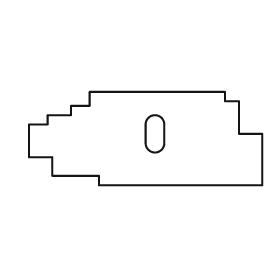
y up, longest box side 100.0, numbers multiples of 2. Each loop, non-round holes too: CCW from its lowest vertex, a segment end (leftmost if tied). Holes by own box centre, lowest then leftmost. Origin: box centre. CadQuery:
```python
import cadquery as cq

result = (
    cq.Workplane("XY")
    .moveTo(-20.0, -20.0)
    .lineTo(50.0, -20.0)
    .lineTo(50.0, 2.0)
    .lineTo(40.0, 2.0)
    .lineTo(40.0, 16.0)
    .lineTo(34.0, 16.0)
    .lineTo(34.0, 20.0)
    .lineTo(-24.0, 20.0)
    .lineTo(-24.0, 14.0)
    .lineTo(-32.0, 14.0)
    .lineTo(-32.0, 10.0)
    .lineTo(-42.0, 10.0)
    .lineTo(-42.0, 6.0)
    .lineTo(-50.0, 6.0)
    .lineTo(-50.0, -8.0)
    .lineTo(-40.0, -8.0)
    .lineTo(-40.0, -16.0)
    .lineTo(-20.0, -16.0)
    .close()
    .moveTo(0.0, -2.0)
    .threePointArc((4.0, -6.0), (8.0, -2.0))
    .lineTo(8.0, 6.0)
    .threePointArc((4.0, 10.0), (0.0, 6.0))
    .close()
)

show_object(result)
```